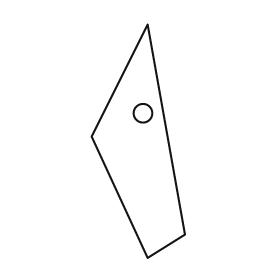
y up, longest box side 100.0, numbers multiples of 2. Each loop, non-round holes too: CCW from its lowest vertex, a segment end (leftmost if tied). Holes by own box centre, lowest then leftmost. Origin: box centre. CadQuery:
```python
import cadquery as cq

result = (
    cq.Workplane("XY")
    .moveTo(4.0, -50.0)
    .lineTo(20.0, -40.0)
    .lineTo(4.0, 50.0)
    .lineTo(-20.0, 2.0)
    .close()
    .moveTo(2.0, 12.0)
    .circle(4.0)
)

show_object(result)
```